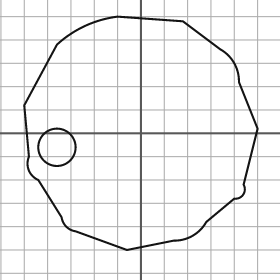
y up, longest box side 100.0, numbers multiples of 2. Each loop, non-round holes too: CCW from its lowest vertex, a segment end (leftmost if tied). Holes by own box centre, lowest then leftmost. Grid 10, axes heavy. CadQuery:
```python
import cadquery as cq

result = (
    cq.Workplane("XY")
    .moveTo(-6.0, -50.0)
    .lineTo(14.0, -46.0)
    .threePointArc((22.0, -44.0), (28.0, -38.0))
    .lineTo(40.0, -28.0)
    .threePointArc((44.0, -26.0), (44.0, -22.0))
    .lineTo(50.0, 2.0)
    .lineTo(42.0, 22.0)
    .threePointArc((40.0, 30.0), (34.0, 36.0))
    .lineTo(18.0, 48.0)
    .lineTo(-10.0, 50.0)
    .threePointArc((-24.0, 46.0), (-36.0, 38.0))
    .lineTo(-50.0, 12.0)
    .lineTo(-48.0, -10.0)
    .threePointArc((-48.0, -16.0), (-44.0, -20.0))
    .lineTo(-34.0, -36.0)
    .threePointArc((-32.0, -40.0), (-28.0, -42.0))
    .close()
    .moveTo(-36.0, -6.0)
    .circle(8.0)
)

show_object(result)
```